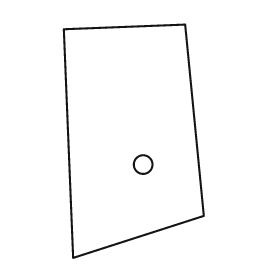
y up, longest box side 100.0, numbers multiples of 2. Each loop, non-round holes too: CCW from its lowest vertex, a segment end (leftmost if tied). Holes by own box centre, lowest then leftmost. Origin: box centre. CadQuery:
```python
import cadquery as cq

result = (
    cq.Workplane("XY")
    .moveTo(-26.0, -50.0)
    .lineTo(30.0, -32.0)
    .lineTo(22.0, 50.0)
    .lineTo(-30.0, 48.0)
    .close()
    .moveTo(4.0, -10.0)
    .circle(4.0)
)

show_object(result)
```